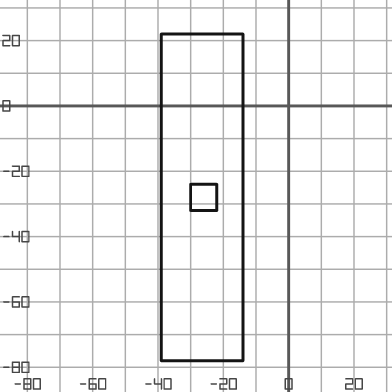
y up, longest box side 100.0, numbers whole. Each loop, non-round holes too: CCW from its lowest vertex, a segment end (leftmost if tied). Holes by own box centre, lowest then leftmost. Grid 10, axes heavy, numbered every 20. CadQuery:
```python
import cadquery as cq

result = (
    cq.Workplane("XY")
    .moveTo(-39.0, -78.0)
    .lineTo(-14.0, -78.0)
    .lineTo(-14.0, 22.0)
    .lineTo(-39.0, 22.0)
    .close()
    .moveTo(-30.0, -32.0)
    .lineTo(-22.0, -32.0)
    .lineTo(-22.0, -24.0)
    .lineTo(-30.0, -24.0)
    .close()
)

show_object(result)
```